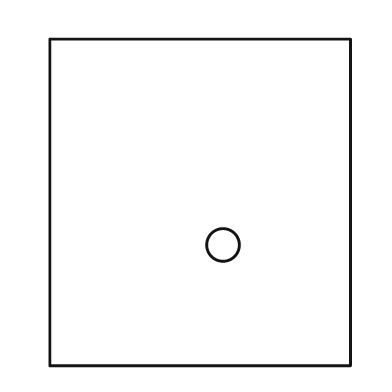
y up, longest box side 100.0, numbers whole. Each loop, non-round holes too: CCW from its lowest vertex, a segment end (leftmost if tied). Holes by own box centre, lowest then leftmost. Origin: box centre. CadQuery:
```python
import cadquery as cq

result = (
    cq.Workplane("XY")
    .moveTo(-46.0, -50.0)
    .lineTo(46.0, -50.0)
    .lineTo(46.0, 50.0)
    .lineTo(-46.0, 50.0)
    .close()
    .moveTo(7.0, -13.0)
    .circle(5.0)
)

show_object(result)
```